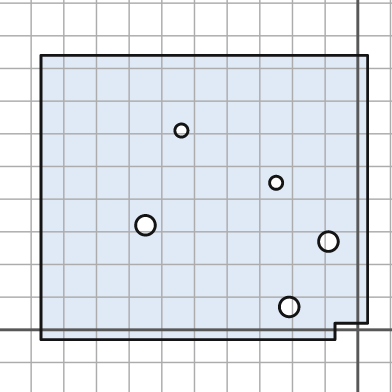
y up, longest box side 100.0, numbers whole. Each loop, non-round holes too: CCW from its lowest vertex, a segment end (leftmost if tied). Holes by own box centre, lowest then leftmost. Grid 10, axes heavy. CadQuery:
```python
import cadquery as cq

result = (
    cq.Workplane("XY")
    .moveTo(-97.0, -3.0)
    .lineTo(-7.0, -3.0)
    .lineTo(-7.0, 2.0)
    .lineTo(3.0, 2.0)
    .lineTo(3.0, 84.0)
    .lineTo(-97.0, 84.0)
    .close()
    .moveTo(-21.0, 7.0)
    .circle(3.0)
    .moveTo(-9.0, 27.0)
    .circle(3.0)
    .moveTo(-65.0, 32.0)
    .circle(3.0)
    .moveTo(-25.0, 45.0)
    .circle(2.0)
    .moveTo(-54.0, 61.0)
    .circle(2.0)
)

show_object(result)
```